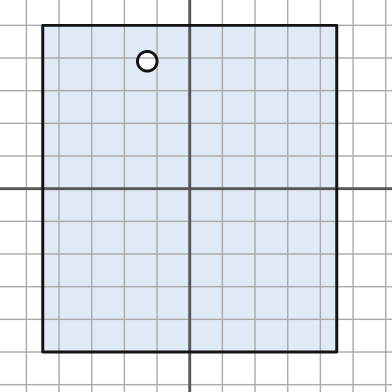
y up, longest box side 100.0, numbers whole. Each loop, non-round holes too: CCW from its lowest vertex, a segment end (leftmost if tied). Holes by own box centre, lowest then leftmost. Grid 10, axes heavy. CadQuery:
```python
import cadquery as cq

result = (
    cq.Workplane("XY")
    .moveTo(-45.0, -50.0)
    .lineTo(45.0, -50.0)
    .lineTo(45.0, 50.0)
    .lineTo(-45.0, 50.0)
    .close()
    .moveTo(-13.0, 39.0)
    .circle(3.0)
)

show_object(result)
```